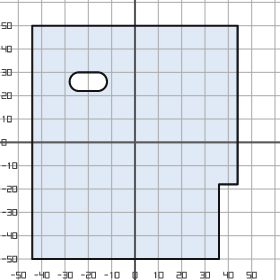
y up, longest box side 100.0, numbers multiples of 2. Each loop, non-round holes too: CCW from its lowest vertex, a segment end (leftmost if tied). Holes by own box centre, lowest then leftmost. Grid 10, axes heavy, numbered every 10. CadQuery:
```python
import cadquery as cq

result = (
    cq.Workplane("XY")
    .moveTo(-44.0, -50.0)
    .lineTo(36.0, -50.0)
    .lineTo(36.0, -18.0)
    .lineTo(44.0, -18.0)
    .lineTo(44.0, 50.0)
    .lineTo(-44.0, 50.0)
    .close()
    .moveTo(-24.0, 22.0)
    .lineTo(-16.0, 22.0)
    .threePointArc((-12.0, 26.0), (-16.0, 30.0))
    .lineTo(-24.0, 30.0)
    .threePointArc((-28.0, 26.0), (-24.0, 22.0))
    .close()
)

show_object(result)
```